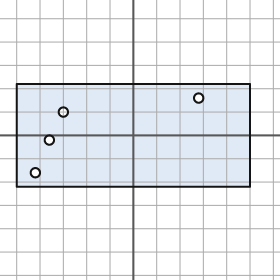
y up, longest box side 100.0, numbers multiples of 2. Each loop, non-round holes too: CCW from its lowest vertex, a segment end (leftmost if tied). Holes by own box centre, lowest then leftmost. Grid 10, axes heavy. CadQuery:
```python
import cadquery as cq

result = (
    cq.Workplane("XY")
    .moveTo(-50.0, -22.0)
    .lineTo(50.0, -22.0)
    .lineTo(50.0, 22.0)
    .lineTo(-50.0, 22.0)
    .close()
    .moveTo(-42.0, -16.0)
    .circle(2.0)
    .moveTo(-36.0, -2.0)
    .circle(2.0)
    .moveTo(-30.0, 10.0)
    .circle(2.0)
    .moveTo(28.0, 16.0)
    .circle(2.0)
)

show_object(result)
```